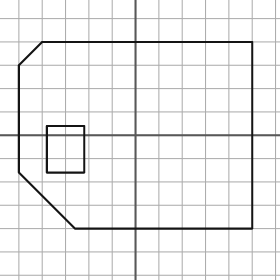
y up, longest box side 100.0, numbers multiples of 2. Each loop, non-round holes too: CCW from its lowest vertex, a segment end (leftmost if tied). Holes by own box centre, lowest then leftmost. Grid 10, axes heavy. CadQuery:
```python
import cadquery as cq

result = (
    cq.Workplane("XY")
    .moveTo(-26.0, -40.0)
    .lineTo(50.0, -40.0)
    .lineTo(50.0, 40.0)
    .lineTo(-40.0, 40.0)
    .lineTo(-50.0, 30.0)
    .lineTo(-50.0, -16.0)
    .close()
    .moveTo(-38.0, -16.0)
    .lineTo(-22.0, -16.0)
    .lineTo(-22.0, 4.0)
    .lineTo(-38.0, 4.0)
    .close()
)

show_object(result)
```